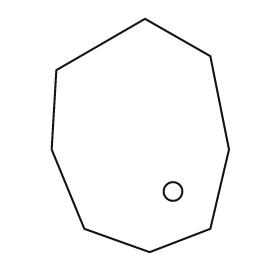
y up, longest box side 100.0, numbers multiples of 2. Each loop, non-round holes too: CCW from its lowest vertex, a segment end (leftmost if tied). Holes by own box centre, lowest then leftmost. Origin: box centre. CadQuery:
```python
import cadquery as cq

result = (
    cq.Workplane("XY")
    .moveTo(4.0, -50.0)
    .lineTo(30.0, -40.0)
    .lineTo(38.0, -6.0)
    .lineTo(30.0, 34.0)
    .lineTo(2.0, 50.0)
    .lineTo(-36.0, 28.0)
    .lineTo(-38.0, -6.0)
    .lineTo(-24.0, -40.0)
    .close()
    .moveTo(14.0, -24.0)
    .circle(4.0)
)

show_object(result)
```